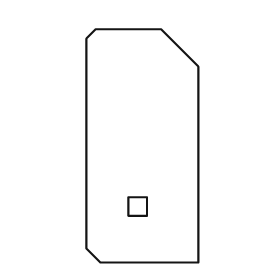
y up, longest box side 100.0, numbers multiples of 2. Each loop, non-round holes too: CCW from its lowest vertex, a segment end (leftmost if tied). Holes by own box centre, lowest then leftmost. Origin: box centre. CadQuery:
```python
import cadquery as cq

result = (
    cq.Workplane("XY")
    .moveTo(-18.0, -50.0)
    .lineTo(24.0, -50.0)
    .lineTo(24.0, 34.0)
    .lineTo(8.0, 50.0)
    .lineTo(-20.0, 50.0)
    .lineTo(-24.0, 46.0)
    .lineTo(-24.0, -44.0)
    .close()
    .moveTo(-6.0, -30.0)
    .lineTo(2.0, -30.0)
    .lineTo(2.0, -22.0)
    .lineTo(-6.0, -22.0)
    .close()
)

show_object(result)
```